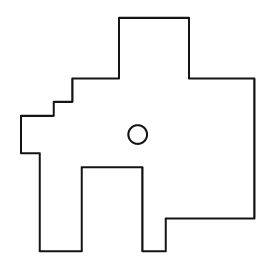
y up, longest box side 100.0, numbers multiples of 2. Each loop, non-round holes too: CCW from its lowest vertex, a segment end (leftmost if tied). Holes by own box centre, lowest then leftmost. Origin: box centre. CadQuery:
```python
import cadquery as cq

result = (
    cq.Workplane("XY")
    .moveTo(-42.0, -50.0)
    .lineTo(-24.0, -50.0)
    .lineTo(-24.0, -14.0)
    .lineTo(2.0, -14.0)
    .lineTo(2.0, -50.0)
    .lineTo(12.0, -50.0)
    .lineTo(12.0, -36.0)
    .lineTo(50.0, -36.0)
    .lineTo(50.0, 24.0)
    .lineTo(22.0, 24.0)
    .lineTo(22.0, 50.0)
    .lineTo(-8.0, 50.0)
    .lineTo(-8.0, 24.0)
    .lineTo(-28.0, 24.0)
    .lineTo(-28.0, 14.0)
    .lineTo(-36.0, 14.0)
    .lineTo(-36.0, 8.0)
    .lineTo(-50.0, 8.0)
    .lineTo(-50.0, -8.0)
    .lineTo(-42.0, -8.0)
    .close()
    .moveTo(0.0, 0.0)
    .circle(4.0)
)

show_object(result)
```